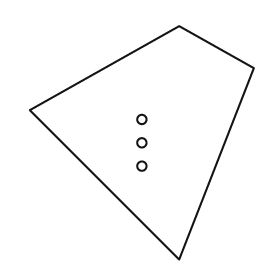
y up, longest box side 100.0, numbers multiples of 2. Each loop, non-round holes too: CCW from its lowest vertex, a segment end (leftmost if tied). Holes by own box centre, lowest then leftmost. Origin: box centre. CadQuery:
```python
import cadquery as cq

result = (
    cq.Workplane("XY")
    .moveTo(16.0, -50.0)
    .lineTo(48.0, 32.0)
    .lineTo(16.0, 50.0)
    .lineTo(-48.0, 14.0)
    .close()
    .moveTo(0.0, -10.0)
    .circle(2.0)
    .moveTo(0.0, 0.0)
    .circle(2.0)
    .moveTo(0.0, 10.0)
    .circle(2.0)
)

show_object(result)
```